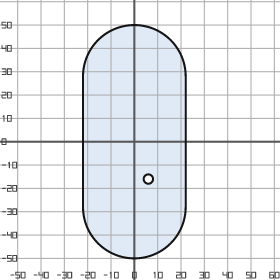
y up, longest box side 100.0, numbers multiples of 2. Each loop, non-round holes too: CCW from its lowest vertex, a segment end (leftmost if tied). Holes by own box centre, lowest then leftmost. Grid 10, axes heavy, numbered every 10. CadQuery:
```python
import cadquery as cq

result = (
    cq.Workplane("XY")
    .moveTo(-22.0, -28.0)
    .threePointArc((0.0, -50.0), (22.0, -28.0))
    .lineTo(22.0, 28.0)
    .threePointArc((0.0, 50.0), (-22.0, 28.0))
    .close()
    .moveTo(6.0, -16.0)
    .circle(2.0)
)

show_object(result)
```